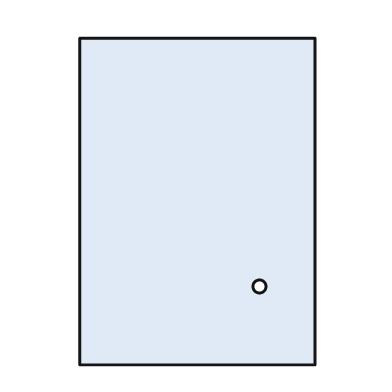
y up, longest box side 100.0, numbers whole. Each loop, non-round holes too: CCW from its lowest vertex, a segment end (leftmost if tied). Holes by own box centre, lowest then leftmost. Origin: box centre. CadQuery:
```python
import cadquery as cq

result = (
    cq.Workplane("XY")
    .moveTo(-36.0, -50.0)
    .lineTo(36.0, -50.0)
    .lineTo(36.0, 50.0)
    .lineTo(-36.0, 50.0)
    .close()
    .moveTo(19.0, -26.0)
    .circle(2.0)
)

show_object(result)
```